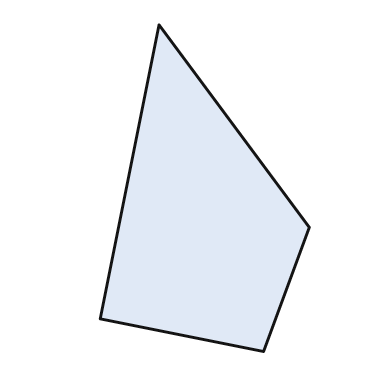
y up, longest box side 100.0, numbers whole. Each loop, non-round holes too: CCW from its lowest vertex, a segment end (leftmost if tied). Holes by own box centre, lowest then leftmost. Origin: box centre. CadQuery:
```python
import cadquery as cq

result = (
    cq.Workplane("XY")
    .moveTo(18.0, -50.0)
    .lineTo(32.0, -12.0)
    .lineTo(-14.0, 50.0)
    .lineTo(-32.0, -40.0)
    .close()
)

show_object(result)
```